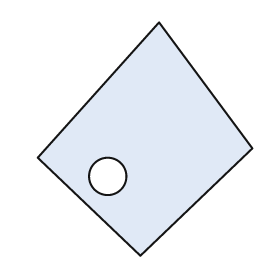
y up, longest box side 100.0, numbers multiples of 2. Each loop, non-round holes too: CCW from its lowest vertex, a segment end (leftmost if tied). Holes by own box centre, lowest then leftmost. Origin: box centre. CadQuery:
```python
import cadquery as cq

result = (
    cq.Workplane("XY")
    .moveTo(-2.0, -50.0)
    .lineTo(46.0, -4.0)
    .lineTo(6.0, 50.0)
    .lineTo(-46.0, -8.0)
    .close()
    .moveTo(-16.0, -16.0)
    .circle(8.0)
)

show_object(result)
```